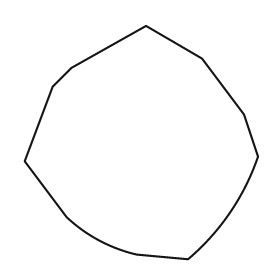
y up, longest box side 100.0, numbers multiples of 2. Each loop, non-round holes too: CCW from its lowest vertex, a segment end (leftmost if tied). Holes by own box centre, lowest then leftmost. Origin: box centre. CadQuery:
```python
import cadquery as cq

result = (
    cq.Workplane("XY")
    .moveTo(20.0, -50.0)
    .threePointArc((38.0, -30.0), (50.0, -6.0))
    .lineTo(44.0, 12.0)
    .lineTo(26.0, 36.0)
    .lineTo(2.0, 50.0)
    .lineTo(-30.0, 32.0)
    .lineTo(-38.0, 24.0)
    .lineTo(-50.0, -8.0)
    .lineTo(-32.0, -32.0)
    .threePointArc((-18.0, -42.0), (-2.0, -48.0))
    .close()
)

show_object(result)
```